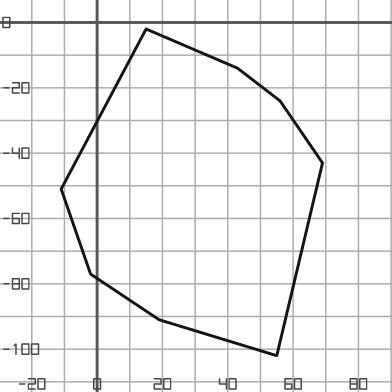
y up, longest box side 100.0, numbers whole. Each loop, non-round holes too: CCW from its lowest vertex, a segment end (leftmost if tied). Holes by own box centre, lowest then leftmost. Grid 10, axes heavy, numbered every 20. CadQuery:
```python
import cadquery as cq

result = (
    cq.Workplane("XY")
    .moveTo(55.0, -102.0)
    .lineTo(69.0, -43.0)
    .lineTo(56.0, -24.0)
    .lineTo(43.0, -14.0)
    .lineTo(15.0, -2.0)
    .lineTo(-11.0, -51.0)
    .lineTo(-2.0, -77.0)
    .lineTo(19.0, -91.0)
    .close()
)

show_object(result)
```